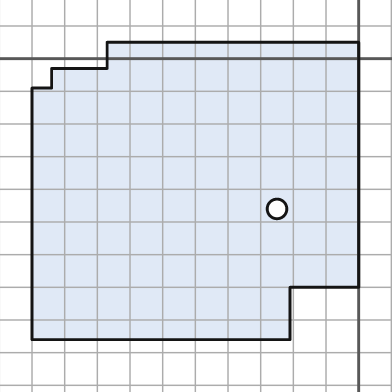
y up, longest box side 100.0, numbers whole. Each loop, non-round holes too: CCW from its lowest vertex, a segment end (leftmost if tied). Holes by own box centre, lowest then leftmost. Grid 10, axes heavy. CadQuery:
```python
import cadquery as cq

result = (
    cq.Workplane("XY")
    .moveTo(-100.0, -86.0)
    .lineTo(-21.0, -86.0)
    .lineTo(-21.0, -70.0)
    .lineTo(0.0, -70.0)
    .lineTo(0.0, 5.0)
    .lineTo(-77.0, 5.0)
    .lineTo(-77.0, -3.0)
    .lineTo(-94.0, -3.0)
    .lineTo(-94.0, -9.0)
    .lineTo(-100.0, -9.0)
    .close()
    .moveTo(-25.0, -46.0)
    .circle(3.0)
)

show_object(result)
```